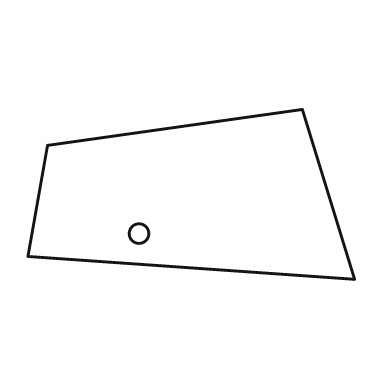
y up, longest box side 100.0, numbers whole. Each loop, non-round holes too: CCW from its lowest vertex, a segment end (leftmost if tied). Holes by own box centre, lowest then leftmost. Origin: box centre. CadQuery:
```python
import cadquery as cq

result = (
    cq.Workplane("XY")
    .moveTo(50.0, -26.0)
    .lineTo(34.0, 26.0)
    .lineTo(-44.0, 15.0)
    .lineTo(-50.0, -19.0)
    .close()
    .moveTo(-16.0, -12.0)
    .circle(3.0)
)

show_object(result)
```